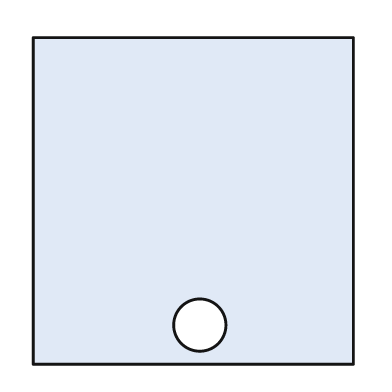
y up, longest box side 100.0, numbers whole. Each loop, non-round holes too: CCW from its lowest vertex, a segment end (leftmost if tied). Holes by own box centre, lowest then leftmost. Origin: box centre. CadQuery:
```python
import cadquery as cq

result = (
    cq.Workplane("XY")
    .moveTo(-49.0, -50.0)
    .lineTo(49.0, -50.0)
    .lineTo(49.0, 50.0)
    .lineTo(-49.0, 50.0)
    .close()
    .moveTo(2.0, -38.0)
    .circle(8.0)
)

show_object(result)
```